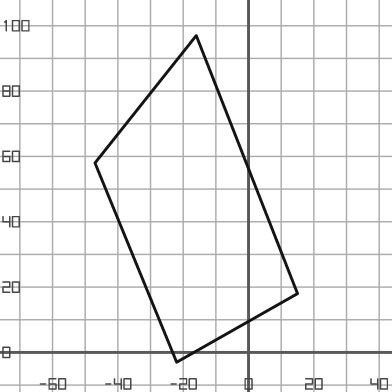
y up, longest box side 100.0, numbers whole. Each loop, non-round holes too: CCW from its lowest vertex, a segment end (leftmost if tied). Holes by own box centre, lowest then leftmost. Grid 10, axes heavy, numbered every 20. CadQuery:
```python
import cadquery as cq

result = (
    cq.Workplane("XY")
    .moveTo(-22.0, -3.0)
    .lineTo(15.0, 18.0)
    .lineTo(-16.0, 97.0)
    .lineTo(-47.0, 58.0)
    .close()
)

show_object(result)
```